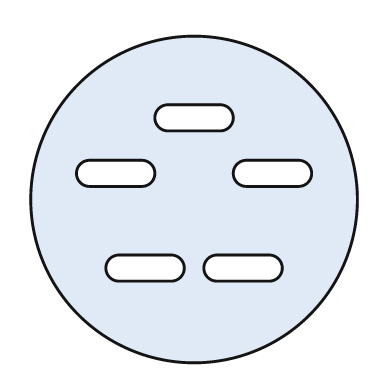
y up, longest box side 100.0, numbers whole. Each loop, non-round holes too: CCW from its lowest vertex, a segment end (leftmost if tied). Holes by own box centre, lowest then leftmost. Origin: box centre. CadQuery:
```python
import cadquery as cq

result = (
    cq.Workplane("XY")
    .moveTo(0.0, 0.0)
    .circle(50.0)
    .moveTo(-23.0, -25.0)
    .lineTo(-7.0, -25.0)
    .threePointArc((-3.0, -21.0), (-7.0, -17.0))
    .lineTo(-23.0, -17.0)
    .threePointArc((-27.0, -21.0), (-23.0, -25.0))
    .close()
    .moveTo(7.0, -25.0)
    .lineTo(23.0, -25.0)
    .threePointArc((27.0, -21.0), (23.0, -17.0))
    .lineTo(7.0, -17.0)
    .threePointArc((3.0, -21.0), (7.0, -25.0))
    .close()
    .moveTo(-32.0, 4.0)
    .lineTo(-16.0, 4.0)
    .threePointArc((-12.0, 8.0), (-16.0, 12.0))
    .lineTo(-32.0, 12.0)
    .threePointArc((-36.0, 8.0), (-32.0, 4.0))
    .close()
    .moveTo(16.0, 4.0)
    .lineTo(32.0, 4.0)
    .threePointArc((36.0, 8.0), (32.0, 12.0))
    .lineTo(16.0, 12.0)
    .threePointArc((12.0, 8.0), (16.0, 4.0))
    .close()
    .moveTo(-8.0, 21.0)
    .lineTo(8.0, 21.0)
    .threePointArc((12.0, 25.0), (8.0, 29.0))
    .lineTo(-8.0, 29.0)
    .threePointArc((-12.0, 25.0), (-8.0, 21.0))
    .close()
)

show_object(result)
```